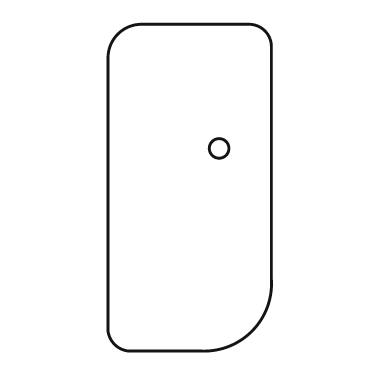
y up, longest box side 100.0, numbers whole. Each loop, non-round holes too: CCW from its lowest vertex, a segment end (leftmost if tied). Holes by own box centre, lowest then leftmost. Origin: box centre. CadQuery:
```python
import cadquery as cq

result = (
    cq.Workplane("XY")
    .moveTo(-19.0, -50.0)
    .lineTo(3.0, -50.0)
    .threePointArc((19.0, -44.0), (25.0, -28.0))
    .lineTo(25.0, 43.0)
    .threePointArc((23.0, 48.0), (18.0, 50.0))
    .lineTo(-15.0, 50.0)
    .threePointArc((-22.0, 47.0), (-25.0, 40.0))
    .lineTo(-25.0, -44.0)
    .threePointArc((-23.0, -48.0), (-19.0, -50.0))
    .close()
    .moveTo(9.0, 12.0)
    .circle(3.0)
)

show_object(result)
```